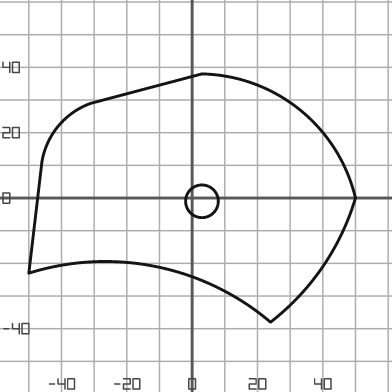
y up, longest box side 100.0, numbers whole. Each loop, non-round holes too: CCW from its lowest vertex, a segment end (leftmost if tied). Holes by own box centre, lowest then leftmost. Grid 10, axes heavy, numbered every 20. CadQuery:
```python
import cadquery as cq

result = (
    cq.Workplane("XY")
    .moveTo(24.0, -38.0)
    .threePointArc((40.0, -21.0), (50.0, 0.0))
    .threePointArc((33.0, 27.0), (3.0, 38.0))
    .lineTo(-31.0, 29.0)
    .threePointArc((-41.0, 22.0), (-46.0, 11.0))
    .lineTo(-50.0, -23.0)
    .threePointArc((-11.0, -21.0), (24.0, -38.0))
    .close()
    .moveTo(3.0, -1.0)
    .circle(5.0)
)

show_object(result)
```